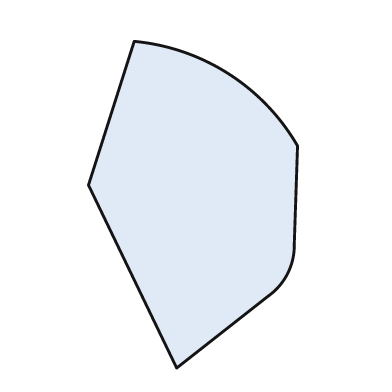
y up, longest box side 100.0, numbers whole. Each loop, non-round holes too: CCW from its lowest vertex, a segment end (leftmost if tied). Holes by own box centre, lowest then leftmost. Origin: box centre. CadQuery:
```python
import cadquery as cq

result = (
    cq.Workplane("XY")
    .moveTo(-5.0, -50.0)
    .lineTo(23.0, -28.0)
    .threePointArc((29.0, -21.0), (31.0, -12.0))
    .lineTo(32.0, 18.0)
    .threePointArc((11.0, 40.0), (-18.0, 50.0))
    .lineTo(-32.0, 6.0)
    .close()
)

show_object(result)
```